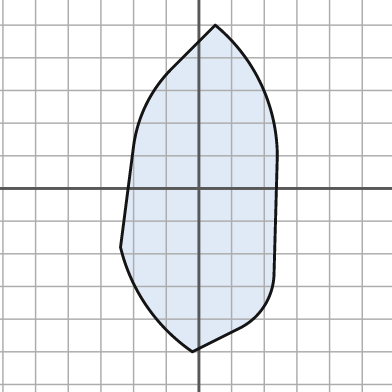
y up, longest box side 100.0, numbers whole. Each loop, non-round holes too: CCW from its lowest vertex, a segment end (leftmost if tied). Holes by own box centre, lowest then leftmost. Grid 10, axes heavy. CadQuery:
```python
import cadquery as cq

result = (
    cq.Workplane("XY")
    .moveTo(-2.0, -50.0)
    .lineTo(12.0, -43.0)
    .threePointArc((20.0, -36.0), (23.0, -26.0))
    .lineTo(24.0, 10.0)
    .threePointArc((19.0, 32.0), (5.0, 50.0))
    .lineTo(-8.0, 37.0)
    .threePointArc((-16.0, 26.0), (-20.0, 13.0))
    .lineTo(-24.0, -18.0)
    .threePointArc((-16.0, -36.0), (-2.0, -50.0))
    .close()
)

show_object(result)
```